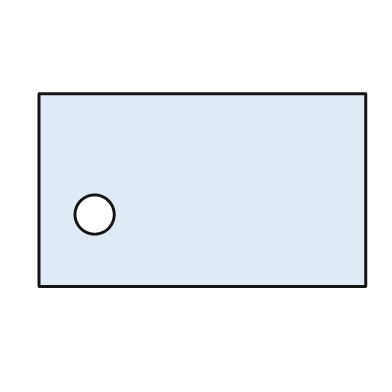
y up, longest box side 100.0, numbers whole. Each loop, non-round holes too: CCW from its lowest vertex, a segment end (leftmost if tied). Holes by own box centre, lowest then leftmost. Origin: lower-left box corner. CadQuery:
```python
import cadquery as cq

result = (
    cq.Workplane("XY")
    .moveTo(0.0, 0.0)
    .lineTo(100.0, 0.0)
    .lineTo(100.0, 59.0)
    .lineTo(0.0, 59.0)
    .close()
    .moveTo(17.0, 22.0)
    .circle(6.0)
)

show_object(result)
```